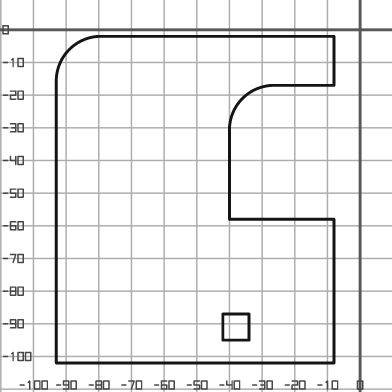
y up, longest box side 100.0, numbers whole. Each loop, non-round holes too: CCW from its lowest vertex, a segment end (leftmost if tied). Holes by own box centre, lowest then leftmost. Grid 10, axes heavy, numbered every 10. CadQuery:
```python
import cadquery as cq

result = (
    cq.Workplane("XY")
    .moveTo(-93.0, -102.0)
    .lineTo(-8.0, -102.0)
    .lineTo(-8.0, -58.0)
    .lineTo(-40.0, -58.0)
    .lineTo(-40.0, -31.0)
    .threePointArc((-36.0, -21.0), (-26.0, -17.0))
    .lineTo(-8.0, -17.0)
    .lineTo(-8.0, -2.0)
    .lineTo(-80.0, -2.0)
    .threePointArc((-89.0, -6.0), (-93.0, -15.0))
    .close()
    .moveTo(-42.0, -95.0)
    .lineTo(-34.0, -95.0)
    .lineTo(-34.0, -87.0)
    .lineTo(-42.0, -87.0)
    .close()
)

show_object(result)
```